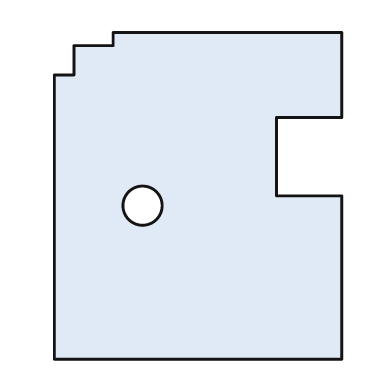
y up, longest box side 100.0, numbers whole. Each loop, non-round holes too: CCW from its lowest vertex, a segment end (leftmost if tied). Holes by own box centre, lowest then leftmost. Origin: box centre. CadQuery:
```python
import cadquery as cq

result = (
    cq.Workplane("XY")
    .moveTo(-44.0, -50.0)
    .lineTo(44.0, -50.0)
    .lineTo(44.0, 0.0)
    .lineTo(24.0, 0.0)
    .lineTo(24.0, 24.0)
    .lineTo(44.0, 24.0)
    .lineTo(44.0, 50.0)
    .lineTo(-26.0, 50.0)
    .lineTo(-26.0, 46.0)
    .lineTo(-38.0, 46.0)
    .lineTo(-38.0, 37.0)
    .lineTo(-44.0, 37.0)
    .close()
    .moveTo(-17.0, -3.0)
    .circle(6.0)
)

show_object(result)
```